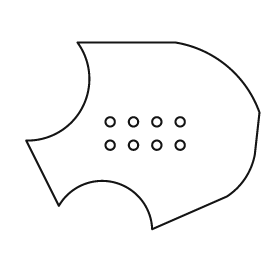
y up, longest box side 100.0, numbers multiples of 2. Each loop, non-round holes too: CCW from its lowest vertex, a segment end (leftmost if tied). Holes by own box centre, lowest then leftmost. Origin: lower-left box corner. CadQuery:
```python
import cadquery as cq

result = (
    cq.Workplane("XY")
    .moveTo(54.0, 0.0)
    .lineTo(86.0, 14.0)
    .threePointArc((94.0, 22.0), (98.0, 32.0))
    .lineTo(100.0, 50.0)
    .threePointArc((86.0, 70.0), (64.0, 80.0))
    .lineTo(22.0, 80.0)
    .threePointArc((24.0, 52.0), (0.0, 38.0))
    .lineTo(14.0, 10.0)
    .threePointArc((38.0, 20.0), (54.0, 0.0))
    .close()
    .moveTo(36.0, 36.0)
    .circle(2.0)
    .moveTo(46.0, 36.0)
    .circle(2.0)
    .moveTo(56.0, 36.0)
    .circle(2.0)
    .moveTo(66.0, 36.0)
    .circle(2.0)
    .moveTo(36.0, 46.0)
    .circle(2.0)
    .moveTo(46.0, 46.0)
    .circle(2.0)
    .moveTo(56.0, 46.0)
    .circle(2.0)
    .moveTo(66.0, 46.0)
    .circle(2.0)
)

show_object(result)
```